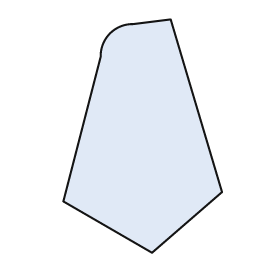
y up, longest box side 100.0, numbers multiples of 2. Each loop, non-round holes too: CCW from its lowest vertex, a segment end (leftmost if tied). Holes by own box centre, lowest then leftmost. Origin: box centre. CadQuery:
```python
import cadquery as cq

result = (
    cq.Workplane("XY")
    .moveTo(4.0, -50.0)
    .lineTo(34.0, -24.0)
    .lineTo(12.0, 50.0)
    .lineTo(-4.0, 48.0)
    .threePointArc((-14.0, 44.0), (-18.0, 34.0))
    .lineTo(-34.0, -28.0)
    .close()
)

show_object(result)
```